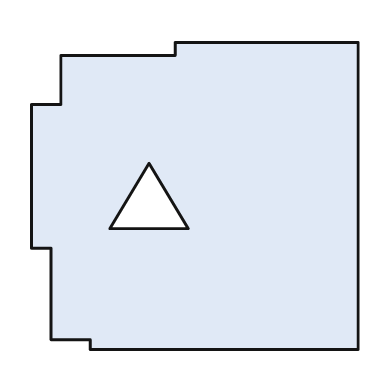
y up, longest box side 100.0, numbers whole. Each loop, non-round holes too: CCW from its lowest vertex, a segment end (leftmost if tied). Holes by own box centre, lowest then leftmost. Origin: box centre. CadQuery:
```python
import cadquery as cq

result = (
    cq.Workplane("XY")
    .moveTo(-32.0, -47.0)
    .lineTo(50.0, -47.0)
    .lineTo(50.0, 47.0)
    .lineTo(-6.0, 47.0)
    .lineTo(-6.0, 43.0)
    .lineTo(-41.0, 43.0)
    .lineTo(-41.0, 28.0)
    .lineTo(-50.0, 28.0)
    .lineTo(-50.0, -16.0)
    .lineTo(-44.0, -16.0)
    .lineTo(-44.0, -44.0)
    .lineTo(-32.0, -44.0)
    .close()
    .moveTo(-26.0, -10.0)
    .lineTo(-2.0, -10.0)
    .lineTo(-14.0, 10.0)
    .close()
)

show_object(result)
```